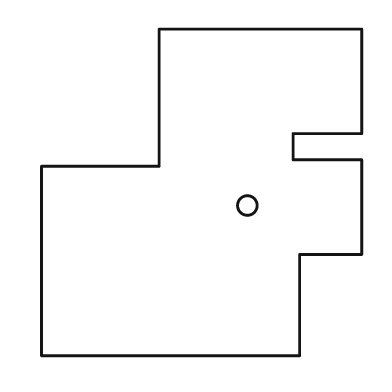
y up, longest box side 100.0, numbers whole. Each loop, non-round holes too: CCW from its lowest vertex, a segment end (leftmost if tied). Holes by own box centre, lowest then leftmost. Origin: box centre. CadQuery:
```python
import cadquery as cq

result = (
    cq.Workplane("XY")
    .moveTo(-49.0, -50.0)
    .lineTo(30.0, -50.0)
    .lineTo(30.0, -19.0)
    .lineTo(49.0, -19.0)
    .lineTo(49.0, 10.0)
    .lineTo(28.0, 10.0)
    .lineTo(28.0, 18.0)
    .lineTo(49.0, 18.0)
    .lineTo(49.0, 50.0)
    .lineTo(-13.0, 50.0)
    .lineTo(-13.0, 8.0)
    .lineTo(-49.0, 8.0)
    .close()
    .moveTo(14.0, -4.0)
    .circle(3.0)
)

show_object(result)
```